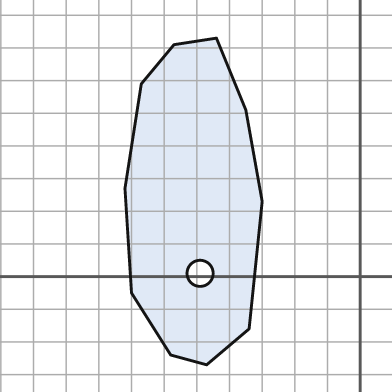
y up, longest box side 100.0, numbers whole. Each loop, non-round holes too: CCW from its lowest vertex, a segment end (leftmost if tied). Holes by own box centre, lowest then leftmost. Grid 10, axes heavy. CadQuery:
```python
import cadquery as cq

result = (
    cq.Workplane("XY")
    .moveTo(-47.0, -27.0)
    .lineTo(-34.0, -16.0)
    .lineTo(-30.0, 23.0)
    .lineTo(-35.0, 51.0)
    .lineTo(-44.0, 73.0)
    .lineTo(-57.0, 71.0)
    .lineTo(-67.0, 59.0)
    .lineTo(-72.0, 27.0)
    .lineTo(-70.0, -5.0)
    .lineTo(-58.0, -24.0)
    .close()
    .moveTo(-49.0, 1.0)
    .circle(4.0)
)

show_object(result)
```